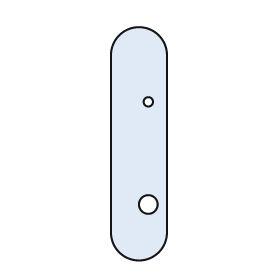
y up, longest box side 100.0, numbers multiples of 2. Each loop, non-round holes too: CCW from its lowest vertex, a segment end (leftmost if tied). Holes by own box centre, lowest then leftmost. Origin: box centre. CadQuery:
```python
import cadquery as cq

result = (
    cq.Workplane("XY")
    .moveTo(-12.0, -38.0)
    .threePointArc((0.0, -50.0), (12.0, -38.0))
    .lineTo(12.0, 38.0)
    .threePointArc((0.0, 50.0), (-12.0, 38.0))
    .close()
    .moveTo(4.0, -26.0)
    .circle(4.0)
    .moveTo(4.0, 18.0)
    .circle(2.0)
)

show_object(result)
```